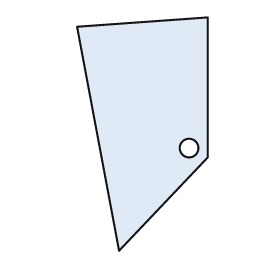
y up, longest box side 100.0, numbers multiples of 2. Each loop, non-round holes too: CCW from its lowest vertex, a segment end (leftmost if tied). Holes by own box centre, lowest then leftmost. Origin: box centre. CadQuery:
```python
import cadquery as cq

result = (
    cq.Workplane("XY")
    .moveTo(-10.0, -50.0)
    .lineTo(28.0, -10.0)
    .lineTo(28.0, 50.0)
    .lineTo(-28.0, 46.0)
    .close()
    .moveTo(20.0, -6.0)
    .circle(4.0)
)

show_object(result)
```